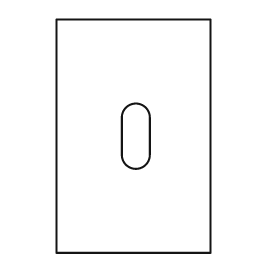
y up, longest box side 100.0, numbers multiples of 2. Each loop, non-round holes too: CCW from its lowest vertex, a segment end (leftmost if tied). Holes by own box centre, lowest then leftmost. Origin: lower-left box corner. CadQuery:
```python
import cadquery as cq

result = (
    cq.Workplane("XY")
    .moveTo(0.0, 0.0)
    .lineTo(66.0, 0.0)
    .lineTo(66.0, 100.0)
    .lineTo(0.0, 100.0)
    .close()
    .moveTo(28.0, 42.0)
    .threePointArc((34.0, 36.0), (40.0, 42.0))
    .lineTo(40.0, 58.0)
    .threePointArc((34.0, 64.0), (28.0, 58.0))
    .close()
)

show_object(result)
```